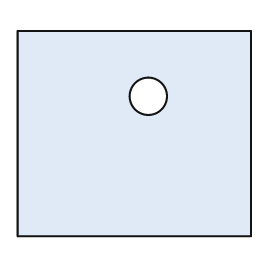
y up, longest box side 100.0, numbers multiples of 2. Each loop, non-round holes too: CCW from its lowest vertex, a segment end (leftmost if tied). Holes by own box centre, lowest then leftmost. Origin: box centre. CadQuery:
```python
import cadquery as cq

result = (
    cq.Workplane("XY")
    .moveTo(-50.0, -44.0)
    .lineTo(50.0, -44.0)
    .lineTo(50.0, 44.0)
    .lineTo(-50.0, 44.0)
    .close()
    .moveTo(6.0, 16.0)
    .circle(8.0)
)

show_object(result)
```